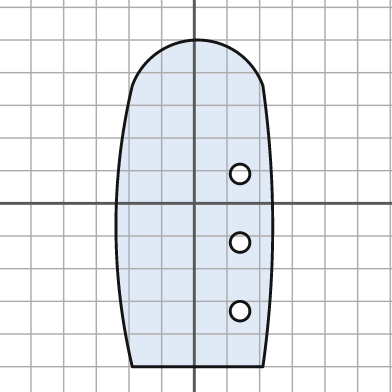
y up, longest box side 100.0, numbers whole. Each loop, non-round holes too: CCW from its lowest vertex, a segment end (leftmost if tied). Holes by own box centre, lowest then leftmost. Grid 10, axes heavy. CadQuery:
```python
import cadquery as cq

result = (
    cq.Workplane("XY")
    .moveTo(-19.0, -50.0)
    .lineTo(21.0, -50.0)
    .threePointArc((24.0, -7.0), (21.0, 36.0))
    .threePointArc((1.0, 50.0), (-19.0, 36.0))
    .threePointArc((-24.0, -7.0), (-19.0, -50.0))
    .close()
    .moveTo(14.0, -33.0)
    .circle(3.0)
    .moveTo(14.0, -12.0)
    .circle(3.0)
    .moveTo(14.0, 9.0)
    .circle(3.0)
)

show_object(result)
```